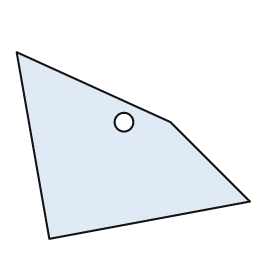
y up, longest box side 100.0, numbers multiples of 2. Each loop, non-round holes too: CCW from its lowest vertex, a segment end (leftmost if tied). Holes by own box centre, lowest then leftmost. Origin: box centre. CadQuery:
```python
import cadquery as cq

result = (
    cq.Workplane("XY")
    .moveTo(-36.0, -40.0)
    .lineTo(50.0, -24.0)
    .lineTo(16.0, 10.0)
    .lineTo(-50.0, 40.0)
    .close()
    .moveTo(-4.0, 10.0)
    .circle(4.0)
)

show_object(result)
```